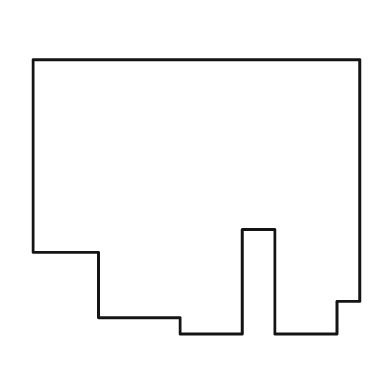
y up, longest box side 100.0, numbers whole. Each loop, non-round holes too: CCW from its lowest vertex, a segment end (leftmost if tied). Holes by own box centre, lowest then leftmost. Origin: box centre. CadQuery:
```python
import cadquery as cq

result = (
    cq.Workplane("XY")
    .moveTo(-5.0, -42.0)
    .lineTo(14.0, -42.0)
    .lineTo(14.0, -10.0)
    .lineTo(24.0, -10.0)
    .lineTo(24.0, -42.0)
    .lineTo(43.0, -42.0)
    .lineTo(43.0, -32.0)
    .lineTo(50.0, -32.0)
    .lineTo(50.0, 42.0)
    .lineTo(-50.0, 42.0)
    .lineTo(-50.0, -17.0)
    .lineTo(-30.0, -17.0)
    .lineTo(-30.0, -37.0)
    .lineTo(-5.0, -37.0)
    .close()
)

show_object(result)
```